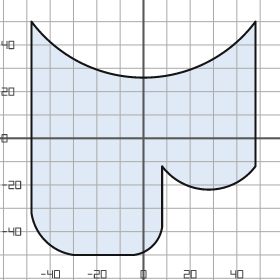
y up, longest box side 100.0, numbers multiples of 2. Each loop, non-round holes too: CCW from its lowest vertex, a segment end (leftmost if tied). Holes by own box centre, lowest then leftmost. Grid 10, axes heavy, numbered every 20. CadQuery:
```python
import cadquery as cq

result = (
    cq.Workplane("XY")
    .moveTo(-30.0, -50.0)
    .lineTo(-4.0, -50.0)
    .threePointArc((4.0, -46.0), (8.0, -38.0))
    .lineTo(8.0, -12.0)
    .threePointArc((28.0, -22.0), (48.0, -12.0))
    .lineTo(48.0, 50.0)
    .threePointArc((0.0, 26.0), (-48.0, 50.0))
    .lineTo(-48.0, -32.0)
    .threePointArc((-42.0, -44.0), (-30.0, -50.0))
    .close()
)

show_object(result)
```